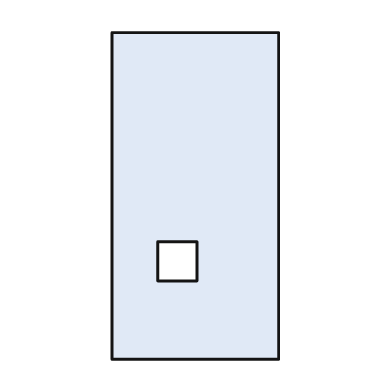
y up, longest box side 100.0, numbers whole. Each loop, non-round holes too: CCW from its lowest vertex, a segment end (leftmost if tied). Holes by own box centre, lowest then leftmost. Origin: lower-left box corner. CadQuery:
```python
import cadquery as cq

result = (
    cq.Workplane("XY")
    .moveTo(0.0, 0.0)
    .lineTo(51.0, 0.0)
    .lineTo(51.0, 100.0)
    .lineTo(0.0, 100.0)
    .close()
    .moveTo(14.0, 24.0)
    .lineTo(26.0, 24.0)
    .lineTo(26.0, 36.0)
    .lineTo(14.0, 36.0)
    .close()
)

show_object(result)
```